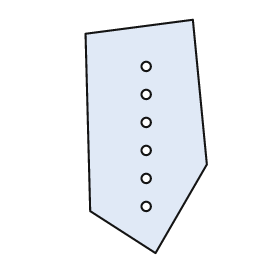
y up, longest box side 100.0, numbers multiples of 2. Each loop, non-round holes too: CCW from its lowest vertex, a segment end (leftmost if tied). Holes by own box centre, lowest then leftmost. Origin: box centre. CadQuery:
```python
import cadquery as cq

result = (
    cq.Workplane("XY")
    .moveTo(4.0, -50.0)
    .lineTo(26.0, -12.0)
    .lineTo(20.0, 50.0)
    .lineTo(-26.0, 44.0)
    .lineTo(-24.0, -32.0)
    .close()
    .moveTo(0.0, -30.0)
    .circle(2.0)
    .moveTo(0.0, -18.0)
    .circle(2.0)
    .moveTo(0.0, -6.0)
    .circle(2.0)
    .moveTo(0.0, 6.0)
    .circle(2.0)
    .moveTo(0.0, 18.0)
    .circle(2.0)
    .moveTo(0.0, 30.0)
    .circle(2.0)
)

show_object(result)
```